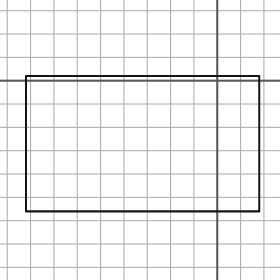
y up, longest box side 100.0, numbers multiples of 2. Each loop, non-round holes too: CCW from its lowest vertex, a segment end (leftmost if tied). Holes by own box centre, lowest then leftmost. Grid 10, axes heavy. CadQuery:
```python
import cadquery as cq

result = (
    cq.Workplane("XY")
    .moveTo(-82.0, -56.0)
    .lineTo(18.0, -56.0)
    .lineTo(18.0, 2.0)
    .lineTo(-82.0, 2.0)
    .close()
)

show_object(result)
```